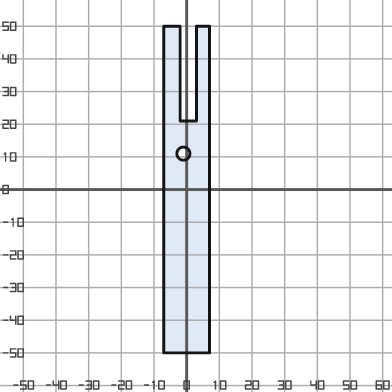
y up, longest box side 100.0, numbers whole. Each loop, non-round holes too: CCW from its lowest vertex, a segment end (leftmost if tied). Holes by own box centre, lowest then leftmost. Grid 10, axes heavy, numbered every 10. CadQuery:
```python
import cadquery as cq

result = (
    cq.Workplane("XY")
    .moveTo(-7.0, -50.0)
    .lineTo(7.0, -50.0)
    .lineTo(7.0, 50.0)
    .lineTo(3.0, 50.0)
    .lineTo(3.0, 21.0)
    .lineTo(-2.0, 21.0)
    .lineTo(-2.0, 50.0)
    .lineTo(-7.0, 50.0)
    .close()
    .moveTo(-1.0, 11.0)
    .circle(2.0)
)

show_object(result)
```